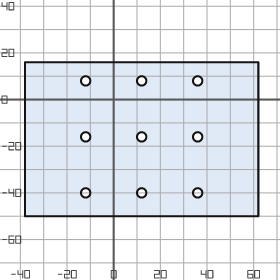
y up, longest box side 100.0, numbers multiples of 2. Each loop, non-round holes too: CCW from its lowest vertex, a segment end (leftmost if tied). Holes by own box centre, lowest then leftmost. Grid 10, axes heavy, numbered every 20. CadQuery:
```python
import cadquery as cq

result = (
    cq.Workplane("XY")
    .moveTo(-38.0, -50.0)
    .lineTo(62.0, -50.0)
    .lineTo(62.0, 16.0)
    .lineTo(-38.0, 16.0)
    .close()
    .moveTo(-12.0, -40.0)
    .circle(2.0)
    .moveTo(12.0, -40.0)
    .circle(2.0)
    .moveTo(36.0, -40.0)
    .circle(2.0)
    .moveTo(-12.0, -16.0)
    .circle(2.0)
    .moveTo(12.0, -16.0)
    .circle(2.0)
    .moveTo(36.0, -16.0)
    .circle(2.0)
    .moveTo(-12.0, 8.0)
    .circle(2.0)
    .moveTo(12.0, 8.0)
    .circle(2.0)
    .moveTo(36.0, 8.0)
    .circle(2.0)
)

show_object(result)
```